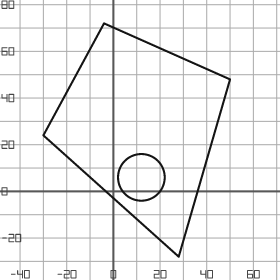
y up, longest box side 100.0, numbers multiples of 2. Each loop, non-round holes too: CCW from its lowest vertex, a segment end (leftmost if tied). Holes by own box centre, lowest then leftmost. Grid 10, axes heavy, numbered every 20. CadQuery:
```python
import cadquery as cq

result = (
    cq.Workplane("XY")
    .moveTo(28.0, -28.0)
    .lineTo(50.0, 48.0)
    .lineTo(-4.0, 72.0)
    .lineTo(-30.0, 24.0)
    .close()
    .moveTo(12.0, 6.0)
    .circle(10.0)
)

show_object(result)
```